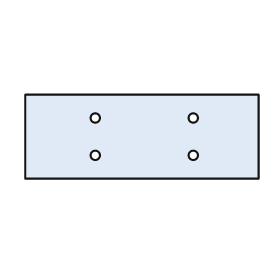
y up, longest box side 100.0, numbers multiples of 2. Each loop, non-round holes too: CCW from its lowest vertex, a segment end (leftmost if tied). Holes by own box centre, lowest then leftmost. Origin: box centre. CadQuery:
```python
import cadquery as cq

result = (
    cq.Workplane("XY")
    .moveTo(-50.0, -18.0)
    .lineTo(50.0, -18.0)
    .lineTo(50.0, 18.0)
    .lineTo(-50.0, 18.0)
    .close()
    .moveTo(-20.0, -8.0)
    .circle(2.0)
    .moveTo(22.0, -8.0)
    .circle(2.0)
    .moveTo(-20.0, 8.0)
    .circle(2.0)
    .moveTo(22.0, 8.0)
    .circle(2.0)
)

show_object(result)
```